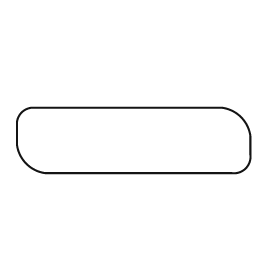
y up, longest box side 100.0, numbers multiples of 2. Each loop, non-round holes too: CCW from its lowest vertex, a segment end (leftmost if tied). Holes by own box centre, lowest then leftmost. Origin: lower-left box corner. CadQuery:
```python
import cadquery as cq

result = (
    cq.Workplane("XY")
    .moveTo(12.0, 0.0)
    .lineTo(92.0, 0.0)
    .threePointArc((98.0, 2.0), (100.0, 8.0))
    .lineTo(100.0, 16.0)
    .threePointArc((96.0, 24.0), (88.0, 28.0))
    .lineTo(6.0, 28.0)
    .threePointArc((2.0, 26.0), (0.0, 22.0))
    .lineTo(0.0, 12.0)
    .threePointArc((4.0, 4.0), (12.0, 0.0))
    .close()
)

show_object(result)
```